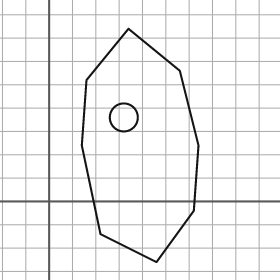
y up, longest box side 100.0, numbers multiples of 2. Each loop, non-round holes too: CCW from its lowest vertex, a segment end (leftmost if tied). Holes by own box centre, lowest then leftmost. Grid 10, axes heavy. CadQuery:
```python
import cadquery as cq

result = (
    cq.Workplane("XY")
    .moveTo(46.0, -26.0)
    .lineTo(62.0, -4.0)
    .lineTo(64.0, 24.0)
    .lineTo(56.0, 56.0)
    .lineTo(34.0, 74.0)
    .lineTo(16.0, 52.0)
    .lineTo(14.0, 24.0)
    .lineTo(22.0, -14.0)
    .close()
    .moveTo(32.0, 36.0)
    .circle(6.0)
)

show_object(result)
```